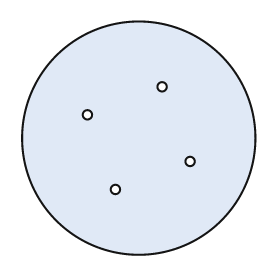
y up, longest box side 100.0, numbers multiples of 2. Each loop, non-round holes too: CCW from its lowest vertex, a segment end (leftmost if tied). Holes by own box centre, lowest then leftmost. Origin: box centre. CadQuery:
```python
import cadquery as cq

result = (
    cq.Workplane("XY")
    .moveTo(0.0, 0.0)
    .circle(50.0)
    .moveTo(-10.0, -22.0)
    .circle(2.0)
    .moveTo(22.0, -10.0)
    .circle(2.0)
    .moveTo(-22.0, 10.0)
    .circle(2.0)
    .moveTo(10.0, 22.0)
    .circle(2.0)
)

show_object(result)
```